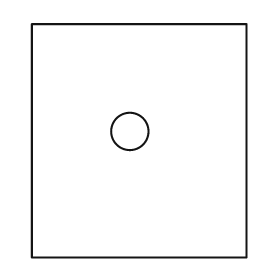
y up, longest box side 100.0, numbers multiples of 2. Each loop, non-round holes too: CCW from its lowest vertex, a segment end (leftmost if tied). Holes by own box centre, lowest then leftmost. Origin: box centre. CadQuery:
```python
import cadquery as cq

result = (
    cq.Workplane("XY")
    .moveTo(-46.0, -50.0)
    .lineTo(46.0, -50.0)
    .lineTo(46.0, 50.0)
    .lineTo(-46.0, 50.0)
    .close()
    .moveTo(-4.0, 4.0)
    .circle(8.0)
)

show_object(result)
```